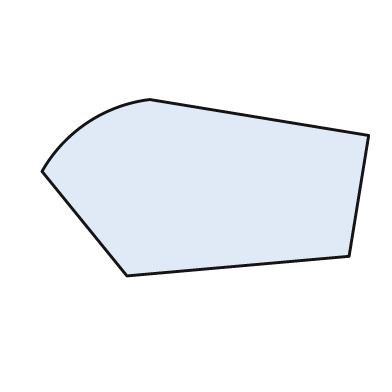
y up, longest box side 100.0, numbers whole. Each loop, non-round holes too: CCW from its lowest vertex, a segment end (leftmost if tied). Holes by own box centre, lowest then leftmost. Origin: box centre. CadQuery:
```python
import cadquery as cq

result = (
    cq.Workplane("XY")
    .moveTo(-24.0, -27.0)
    .lineTo(44.0, -21.0)
    .lineTo(50.0, 16.0)
    .lineTo(-17.0, 27.0)
    .threePointArc((-36.0, 20.0), (-50.0, 5.0))
    .close()
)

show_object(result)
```